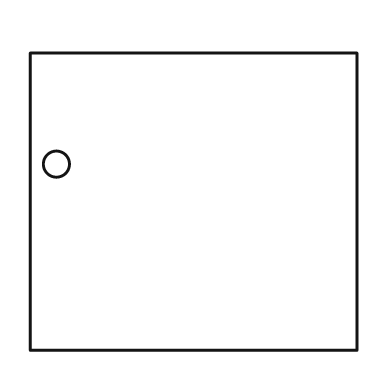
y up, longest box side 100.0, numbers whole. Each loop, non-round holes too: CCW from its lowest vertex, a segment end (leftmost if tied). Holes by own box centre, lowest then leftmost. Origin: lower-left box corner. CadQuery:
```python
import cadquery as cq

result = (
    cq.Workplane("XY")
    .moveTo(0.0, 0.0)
    .lineTo(100.0, 0.0)
    .lineTo(100.0, 91.0)
    .lineTo(0.0, 91.0)
    .close()
    .moveTo(8.0, 57.0)
    .circle(4.0)
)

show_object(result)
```